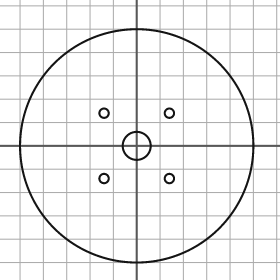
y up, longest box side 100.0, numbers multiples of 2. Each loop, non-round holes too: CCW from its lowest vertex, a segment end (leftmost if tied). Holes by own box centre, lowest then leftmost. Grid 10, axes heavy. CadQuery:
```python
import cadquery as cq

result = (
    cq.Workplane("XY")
    .moveTo(0.0, 0.0)
    .circle(50.0)
    .moveTo(-14.0, -14.0)
    .circle(2.0)
    .moveTo(14.0, -14.0)
    .circle(2.0)
    .moveTo(0.0, 0.0)
    .circle(6.0)
    .moveTo(-14.0, 14.0)
    .circle(2.0)
    .moveTo(14.0, 14.0)
    .circle(2.0)
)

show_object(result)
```